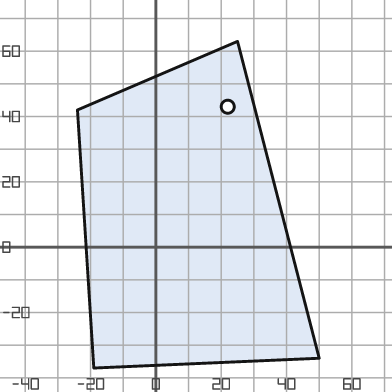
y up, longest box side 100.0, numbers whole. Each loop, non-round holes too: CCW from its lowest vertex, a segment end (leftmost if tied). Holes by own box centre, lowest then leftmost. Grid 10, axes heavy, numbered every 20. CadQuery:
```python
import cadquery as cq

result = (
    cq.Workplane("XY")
    .moveTo(-19.0, -37.0)
    .lineTo(50.0, -34.0)
    .lineTo(25.0, 63.0)
    .lineTo(-24.0, 42.0)
    .close()
    .moveTo(22.0, 43.0)
    .circle(2.0)
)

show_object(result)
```